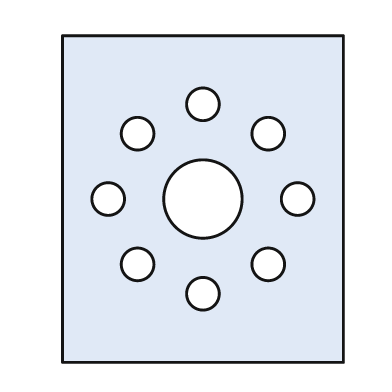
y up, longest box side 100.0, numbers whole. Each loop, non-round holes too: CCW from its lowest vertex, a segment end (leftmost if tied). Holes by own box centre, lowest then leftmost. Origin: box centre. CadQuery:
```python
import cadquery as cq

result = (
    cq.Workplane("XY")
    .moveTo(-43.0, -50.0)
    .lineTo(43.0, -50.0)
    .lineTo(43.0, 50.0)
    .lineTo(-43.0, 50.0)
    .close()
    .moveTo(0.0, -29.0)
    .circle(5.0)
    .moveTo(-20.0, -20.0)
    .circle(5.0)
    .moveTo(20.0, -20.0)
    .circle(5.0)
    .moveTo(-29.0, 0.0)
    .circle(5.0)
    .moveTo(0.0, 0.0)
    .circle(12.0)
    .moveTo(29.0, 0.0)
    .circle(5.0)
    .moveTo(-20.0, 20.0)
    .circle(5.0)
    .moveTo(20.0, 20.0)
    .circle(5.0)
    .moveTo(0.0, 29.0)
    .circle(5.0)
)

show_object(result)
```